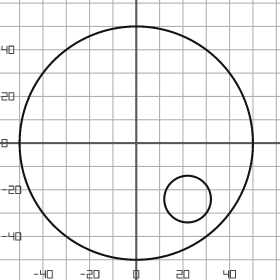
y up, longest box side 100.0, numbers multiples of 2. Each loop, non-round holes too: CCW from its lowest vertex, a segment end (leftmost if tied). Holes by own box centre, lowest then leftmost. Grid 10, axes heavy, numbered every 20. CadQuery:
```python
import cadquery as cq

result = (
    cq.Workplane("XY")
    .moveTo(0.0, 0.0)
    .circle(50.0)
    .moveTo(22.0, -24.0)
    .circle(10.0)
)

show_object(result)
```